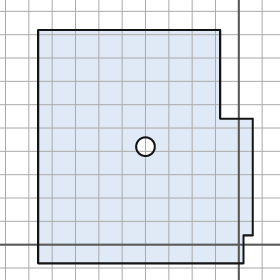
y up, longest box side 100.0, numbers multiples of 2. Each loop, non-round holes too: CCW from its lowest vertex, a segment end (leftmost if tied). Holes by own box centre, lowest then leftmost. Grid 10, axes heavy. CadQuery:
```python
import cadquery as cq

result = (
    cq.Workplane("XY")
    .moveTo(-86.0, -8.0)
    .lineTo(2.0, -8.0)
    .lineTo(2.0, 4.0)
    .lineTo(6.0, 4.0)
    .lineTo(6.0, 54.0)
    .lineTo(-8.0, 54.0)
    .lineTo(-8.0, 92.0)
    .lineTo(-86.0, 92.0)
    .close()
    .moveTo(-40.0, 42.0)
    .circle(4.0)
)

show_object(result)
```